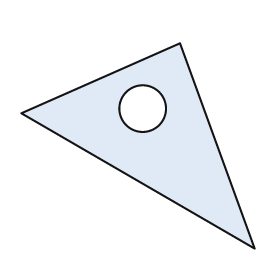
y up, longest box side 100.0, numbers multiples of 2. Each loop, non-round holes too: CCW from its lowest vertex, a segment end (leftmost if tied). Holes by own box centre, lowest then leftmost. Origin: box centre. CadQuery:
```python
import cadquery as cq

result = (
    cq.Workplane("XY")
    .moveTo(50.0, -44.0)
    .lineTo(18.0, 44.0)
    .lineTo(-50.0, 14.0)
    .close()
    .moveTo(2.0, 16.0)
    .circle(10.0)
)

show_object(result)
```